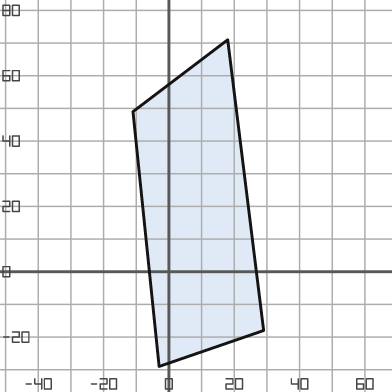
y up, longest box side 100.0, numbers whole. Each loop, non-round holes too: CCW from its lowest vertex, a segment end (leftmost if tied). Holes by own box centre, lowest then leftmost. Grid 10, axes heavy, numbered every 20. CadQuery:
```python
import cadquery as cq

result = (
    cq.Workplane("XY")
    .moveTo(-3.0, -29.0)
    .lineTo(29.0, -18.0)
    .lineTo(18.0, 71.0)
    .lineTo(-11.0, 49.0)
    .close()
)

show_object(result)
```